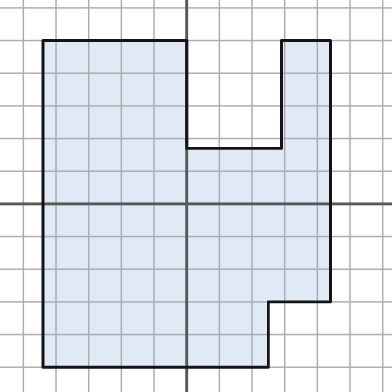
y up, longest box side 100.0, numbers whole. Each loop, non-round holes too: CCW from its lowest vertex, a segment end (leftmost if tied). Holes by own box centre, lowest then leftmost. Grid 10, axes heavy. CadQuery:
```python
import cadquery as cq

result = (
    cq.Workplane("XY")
    .moveTo(-44.0, -50.0)
    .lineTo(25.0, -50.0)
    .lineTo(25.0, -30.0)
    .lineTo(44.0, -30.0)
    .lineTo(44.0, 50.0)
    .lineTo(29.0, 50.0)
    .lineTo(29.0, 17.0)
    .lineTo(0.0, 17.0)
    .lineTo(0.0, 50.0)
    .lineTo(-44.0, 50.0)
    .close()
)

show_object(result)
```